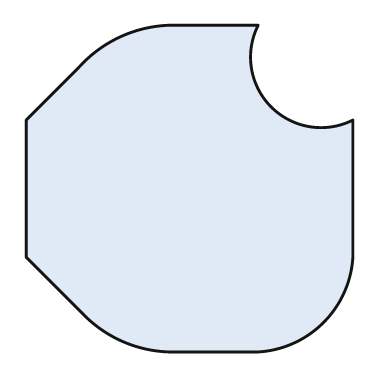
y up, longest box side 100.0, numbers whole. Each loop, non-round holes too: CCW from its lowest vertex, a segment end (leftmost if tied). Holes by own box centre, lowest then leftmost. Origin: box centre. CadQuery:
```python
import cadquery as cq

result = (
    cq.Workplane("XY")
    .moveTo(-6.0, -50.0)
    .lineTo(21.0, -50.0)
    .threePointArc((41.0, -41.0), (50.0, -21.0))
    .lineTo(50.0, 21.0)
    .threePointArc((25.0, 25.0), (21.0, 50.0))
    .lineTo(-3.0, 50.0)
    .threePointArc((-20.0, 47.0), (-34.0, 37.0))
    .lineTo(-50.0, 21.0)
    .lineTo(-50.0, -21.0)
    .lineTo(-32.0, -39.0)
    .threePointArc((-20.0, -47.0), (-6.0, -50.0))
    .close()
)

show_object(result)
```